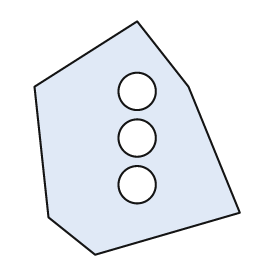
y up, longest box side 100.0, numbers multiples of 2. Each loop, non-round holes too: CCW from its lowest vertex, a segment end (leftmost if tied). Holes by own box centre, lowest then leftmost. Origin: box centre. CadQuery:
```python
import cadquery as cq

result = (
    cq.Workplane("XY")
    .moveTo(-18.0, -50.0)
    .lineTo(44.0, -32.0)
    .lineTo(22.0, 22.0)
    .lineTo(0.0, 50.0)
    .lineTo(-44.0, 22.0)
    .lineTo(-38.0, -34.0)
    .close()
    .moveTo(0.0, -20.0)
    .circle(8.0)
    .moveTo(0.0, 0.0)
    .circle(8.0)
    .moveTo(0.0, 20.0)
    .circle(8.0)
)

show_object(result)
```